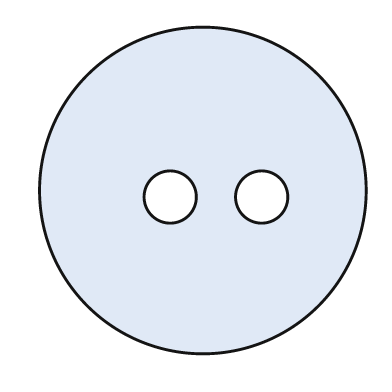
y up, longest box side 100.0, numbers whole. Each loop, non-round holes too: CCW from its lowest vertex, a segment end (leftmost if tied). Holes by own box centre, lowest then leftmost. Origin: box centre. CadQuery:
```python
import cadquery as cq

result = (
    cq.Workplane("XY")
    .moveTo(0.0, 0.0)
    .circle(50.0)
    .moveTo(-10.0, -2.0)
    .circle(8.0)
    .moveTo(18.0, -2.0)
    .circle(8.0)
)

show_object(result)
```